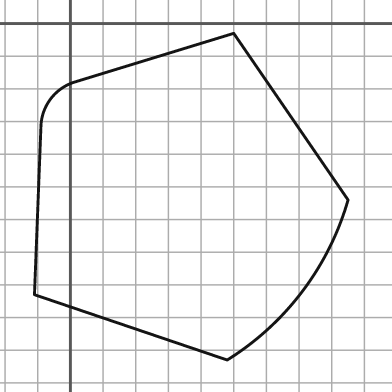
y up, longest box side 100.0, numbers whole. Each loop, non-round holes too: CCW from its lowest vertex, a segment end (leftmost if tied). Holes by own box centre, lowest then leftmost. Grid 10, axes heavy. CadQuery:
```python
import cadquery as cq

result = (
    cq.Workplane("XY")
    .moveTo(48.0, -103.0)
    .threePointArc((71.0, -82.0), (85.0, -54.0))
    .lineTo(50.0, -3.0)
    .lineTo(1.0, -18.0)
    .threePointArc((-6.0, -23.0), (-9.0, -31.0))
    .lineTo(-11.0, -83.0)
    .close()
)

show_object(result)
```